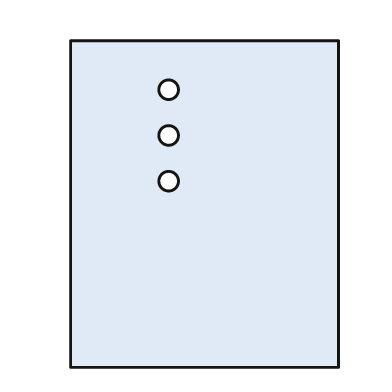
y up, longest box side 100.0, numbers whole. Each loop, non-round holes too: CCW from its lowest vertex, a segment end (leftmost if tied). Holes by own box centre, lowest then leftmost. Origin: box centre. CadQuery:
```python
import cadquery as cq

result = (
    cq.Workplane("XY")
    .moveTo(-41.0, -50.0)
    .lineTo(41.0, -50.0)
    .lineTo(41.0, 50.0)
    .lineTo(-41.0, 50.0)
    .close()
    .moveTo(-11.0, 7.0)
    .circle(3.0)
    .moveTo(-11.0, 21.0)
    .circle(3.0)
    .moveTo(-11.0, 35.0)
    .circle(3.0)
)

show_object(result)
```